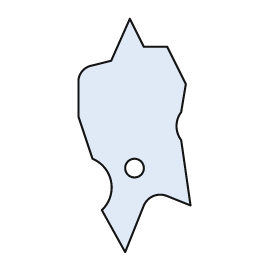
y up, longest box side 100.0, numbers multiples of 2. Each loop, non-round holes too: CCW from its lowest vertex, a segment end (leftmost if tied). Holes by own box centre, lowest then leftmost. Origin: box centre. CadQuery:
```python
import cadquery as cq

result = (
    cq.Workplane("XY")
    .moveTo(-4.0, -50.0)
    .lineTo(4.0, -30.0)
    .threePointArc((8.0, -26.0), (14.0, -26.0))
    .lineTo(24.0, -30.0)
    .lineTo(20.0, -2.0)
    .threePointArc((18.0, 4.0), (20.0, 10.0))
    .lineTo(22.0, 22.0)
    .lineTo(14.0, 38.0)
    .lineTo(4.0, 38.0)
    .lineTo(-2.0, 50.0)
    .lineTo(-10.0, 32.0)
    .lineTo(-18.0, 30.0)
    .threePointArc((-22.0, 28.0), (-24.0, 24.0))
    .lineTo(-24.0, 8.0)
    .lineTo(-18.0, -10.0)
    .threePointArc((-10.0, -20.0), (-14.0, -32.0))
    .close()
    .moveTo(0.0, -14.0)
    .circle(4.0)
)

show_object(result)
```